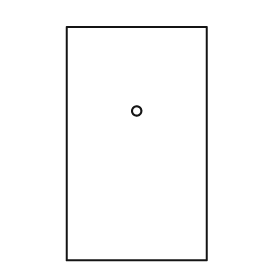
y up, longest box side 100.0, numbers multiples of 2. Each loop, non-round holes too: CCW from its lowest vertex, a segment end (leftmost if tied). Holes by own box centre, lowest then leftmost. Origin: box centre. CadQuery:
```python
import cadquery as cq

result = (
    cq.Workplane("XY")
    .moveTo(-30.0, -50.0)
    .lineTo(30.0, -50.0)
    .lineTo(30.0, 50.0)
    .lineTo(-30.0, 50.0)
    .close()
    .moveTo(0.0, 14.0)
    .circle(2.0)
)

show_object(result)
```